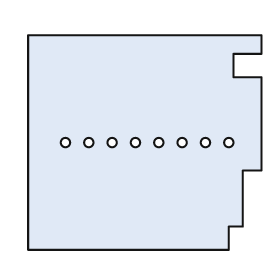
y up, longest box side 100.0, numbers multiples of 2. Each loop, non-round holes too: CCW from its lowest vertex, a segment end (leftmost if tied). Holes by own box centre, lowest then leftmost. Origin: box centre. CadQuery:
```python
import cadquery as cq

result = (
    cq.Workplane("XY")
    .moveTo(-50.0, -46.0)
    .lineTo(36.0, -46.0)
    .lineTo(36.0, -36.0)
    .lineTo(42.0, -36.0)
    .lineTo(42.0, -12.0)
    .lineTo(50.0, -12.0)
    .lineTo(50.0, 28.0)
    .lineTo(38.0, 28.0)
    .lineTo(38.0, 38.0)
    .lineTo(50.0, 38.0)
    .lineTo(50.0, 46.0)
    .lineTo(-50.0, 46.0)
    .close()
    .moveTo(-34.0, 0.0)
    .circle(2.0)
    .moveTo(-24.0, 0.0)
    .circle(2.0)
    .moveTo(-14.0, 0.0)
    .circle(2.0)
    .moveTo(-4.0, 0.0)
    .circle(2.0)
    .moveTo(6.0, 0.0)
    .circle(2.0)
    .moveTo(16.0, 0.0)
    .circle(2.0)
    .moveTo(26.0, 0.0)
    .circle(2.0)
    .moveTo(36.0, 0.0)
    .circle(2.0)
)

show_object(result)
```